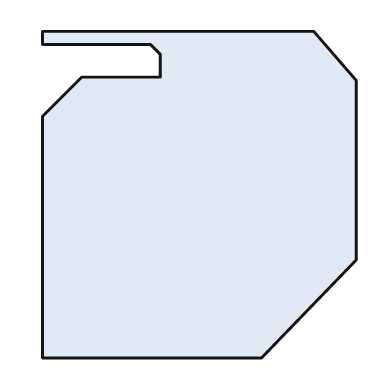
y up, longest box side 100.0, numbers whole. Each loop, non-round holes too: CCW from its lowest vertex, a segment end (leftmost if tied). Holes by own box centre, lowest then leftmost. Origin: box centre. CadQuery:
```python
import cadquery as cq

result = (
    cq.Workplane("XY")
    .moveTo(-48.0, -50.0)
    .lineTo(19.0, -50.0)
    .lineTo(48.0, -20.0)
    .lineTo(48.0, 35.0)
    .lineTo(35.0, 50.0)
    .lineTo(-48.0, 50.0)
    .lineTo(-48.0, 46.0)
    .lineTo(-15.0, 46.0)
    .lineTo(-12.0, 43.0)
    .lineTo(-12.0, 36.0)
    .lineTo(-36.0, 36.0)
    .lineTo(-48.0, 24.0)
    .close()
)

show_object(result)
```